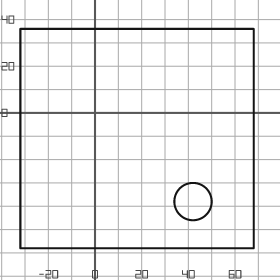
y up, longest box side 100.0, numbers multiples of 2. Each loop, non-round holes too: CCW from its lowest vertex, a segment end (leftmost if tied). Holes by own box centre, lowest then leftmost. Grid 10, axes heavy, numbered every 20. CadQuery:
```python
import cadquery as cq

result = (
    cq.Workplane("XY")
    .moveTo(-32.0, -58.0)
    .lineTo(68.0, -58.0)
    .lineTo(68.0, 36.0)
    .lineTo(-32.0, 36.0)
    .close()
    .moveTo(42.0, -38.0)
    .circle(8.0)
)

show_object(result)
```